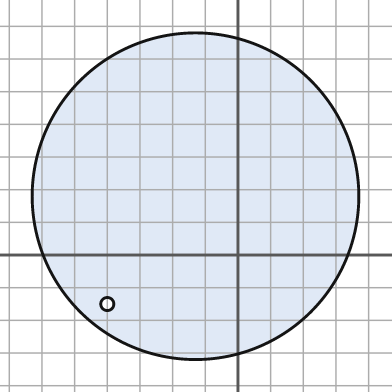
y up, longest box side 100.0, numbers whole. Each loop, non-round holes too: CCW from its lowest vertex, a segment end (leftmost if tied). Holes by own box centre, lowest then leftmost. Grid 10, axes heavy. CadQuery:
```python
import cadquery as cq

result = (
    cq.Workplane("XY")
    .moveTo(-13.0, 18.0)
    .circle(50.0)
    .moveTo(-40.0, -15.0)
    .circle(2.0)
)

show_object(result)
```